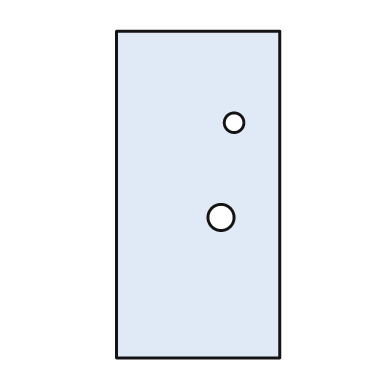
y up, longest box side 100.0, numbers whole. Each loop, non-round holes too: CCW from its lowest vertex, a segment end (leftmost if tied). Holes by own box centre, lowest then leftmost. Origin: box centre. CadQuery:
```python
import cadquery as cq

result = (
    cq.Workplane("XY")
    .moveTo(-25.0, -50.0)
    .lineTo(25.0, -50.0)
    .lineTo(25.0, 50.0)
    .lineTo(-25.0, 50.0)
    .close()
    .moveTo(7.0, -7.0)
    .circle(4.0)
    .moveTo(11.0, 22.0)
    .circle(3.0)
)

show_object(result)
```